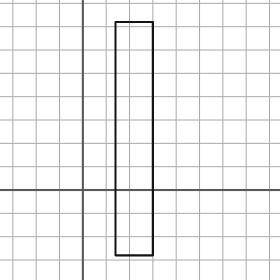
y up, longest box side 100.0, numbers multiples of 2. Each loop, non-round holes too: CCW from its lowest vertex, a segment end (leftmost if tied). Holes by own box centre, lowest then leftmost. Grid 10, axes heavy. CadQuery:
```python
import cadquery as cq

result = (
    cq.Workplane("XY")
    .moveTo(14.0, -28.0)
    .lineTo(30.0, -28.0)
    .lineTo(30.0, 72.0)
    .lineTo(14.0, 72.0)
    .close()
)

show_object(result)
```